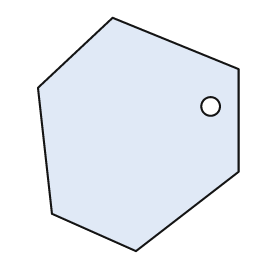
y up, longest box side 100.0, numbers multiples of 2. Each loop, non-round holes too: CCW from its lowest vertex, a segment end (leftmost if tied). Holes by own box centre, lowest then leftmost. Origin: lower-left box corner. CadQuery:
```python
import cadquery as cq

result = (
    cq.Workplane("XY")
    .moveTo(42.0, 0.0)
    .lineTo(86.0, 34.0)
    .lineTo(86.0, 78.0)
    .lineTo(32.0, 100.0)
    .lineTo(0.0, 70.0)
    .lineTo(6.0, 16.0)
    .close()
    .moveTo(74.0, 62.0)
    .circle(4.0)
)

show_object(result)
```